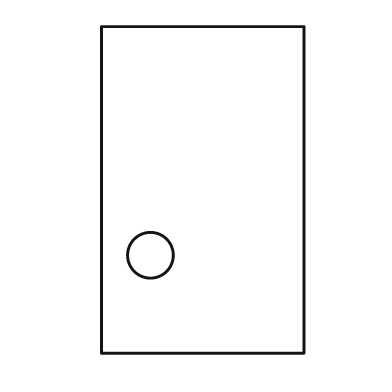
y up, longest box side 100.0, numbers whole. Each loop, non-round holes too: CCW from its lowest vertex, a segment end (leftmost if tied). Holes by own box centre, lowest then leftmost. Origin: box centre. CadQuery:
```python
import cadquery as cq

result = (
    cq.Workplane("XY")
    .moveTo(-31.0, -50.0)
    .lineTo(31.0, -50.0)
    .lineTo(31.0, 50.0)
    .lineTo(-31.0, 50.0)
    .close()
    .moveTo(-16.0, -20.0)
    .circle(7.0)
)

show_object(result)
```